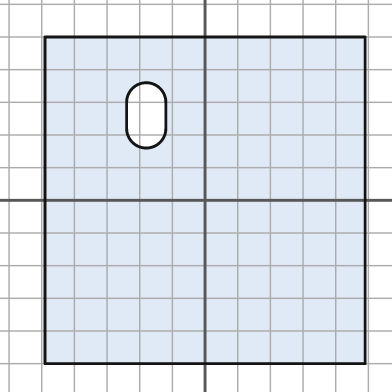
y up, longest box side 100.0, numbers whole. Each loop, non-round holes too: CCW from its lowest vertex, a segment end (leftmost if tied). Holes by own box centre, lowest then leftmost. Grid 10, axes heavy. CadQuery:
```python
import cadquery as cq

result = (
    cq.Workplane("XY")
    .moveTo(-49.0, -50.0)
    .lineTo(49.0, -50.0)
    .lineTo(49.0, 50.0)
    .lineTo(-49.0, 50.0)
    .close()
    .moveTo(-24.0, 22.0)
    .threePointArc((-18.0, 16.0), (-12.0, 22.0))
    .lineTo(-12.0, 30.0)
    .threePointArc((-18.0, 36.0), (-24.0, 30.0))
    .close()
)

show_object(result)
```